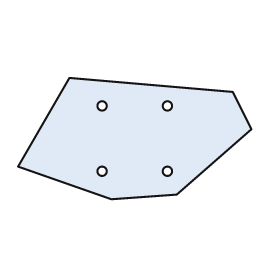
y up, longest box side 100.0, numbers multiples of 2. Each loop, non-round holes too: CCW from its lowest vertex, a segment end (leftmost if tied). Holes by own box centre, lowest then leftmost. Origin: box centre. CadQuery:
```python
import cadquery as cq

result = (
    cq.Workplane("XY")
    .moveTo(-10.0, -26.0)
    .lineTo(18.0, -24.0)
    .lineTo(50.0, 4.0)
    .lineTo(42.0, 20.0)
    .lineTo(-28.0, 26.0)
    .lineTo(-50.0, -12.0)
    .close()
    .moveTo(-14.0, -14.0)
    .circle(2.0)
    .moveTo(14.0, -14.0)
    .circle(2.0)
    .moveTo(-14.0, 14.0)
    .circle(2.0)
    .moveTo(14.0, 14.0)
    .circle(2.0)
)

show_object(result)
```